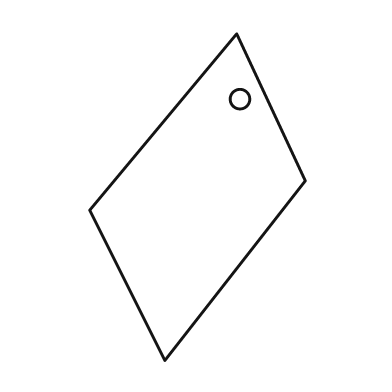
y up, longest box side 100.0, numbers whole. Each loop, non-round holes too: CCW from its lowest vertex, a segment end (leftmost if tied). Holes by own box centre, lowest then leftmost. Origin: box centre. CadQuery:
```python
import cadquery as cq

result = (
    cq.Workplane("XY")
    .moveTo(-10.0, -50.0)
    .lineTo(33.0, 5.0)
    .lineTo(12.0, 50.0)
    .lineTo(-33.0, -4.0)
    .close()
    .moveTo(13.0, 30.0)
    .circle(3.0)
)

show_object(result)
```